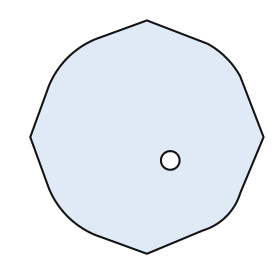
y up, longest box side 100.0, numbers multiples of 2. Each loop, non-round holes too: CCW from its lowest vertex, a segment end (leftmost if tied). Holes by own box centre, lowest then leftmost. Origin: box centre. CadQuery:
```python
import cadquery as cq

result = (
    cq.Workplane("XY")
    .moveTo(0.0, -50.0)
    .lineTo(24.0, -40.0)
    .threePointArc((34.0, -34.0), (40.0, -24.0))
    .lineTo(50.0, 0.0)
    .lineTo(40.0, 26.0)
    .threePointArc((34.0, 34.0), (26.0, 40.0))
    .lineTo(0.0, 50.0)
    .lineTo(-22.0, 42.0)
    .threePointArc((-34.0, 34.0), (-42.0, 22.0))
    .lineTo(-50.0, 0.0)
    .lineTo(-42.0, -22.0)
    .threePointArc((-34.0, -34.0), (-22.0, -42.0))
    .close()
    .moveTo(10.0, -10.0)
    .circle(4.0)
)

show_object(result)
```